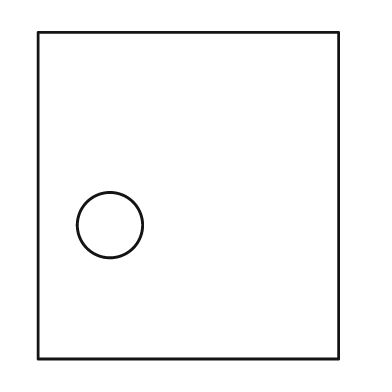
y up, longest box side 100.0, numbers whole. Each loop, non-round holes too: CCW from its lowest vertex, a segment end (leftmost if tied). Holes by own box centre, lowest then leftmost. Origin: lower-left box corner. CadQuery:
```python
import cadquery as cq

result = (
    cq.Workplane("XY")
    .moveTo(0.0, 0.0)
    .lineTo(92.0, 0.0)
    .lineTo(92.0, 100.0)
    .lineTo(0.0, 100.0)
    .close()
    .moveTo(22.0, 41.0)
    .circle(10.0)
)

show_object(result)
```